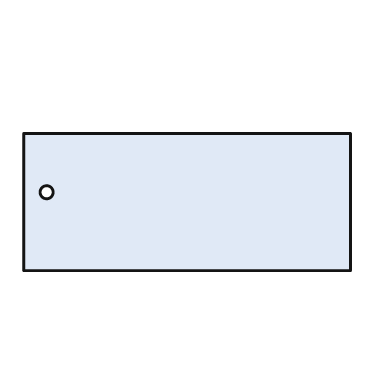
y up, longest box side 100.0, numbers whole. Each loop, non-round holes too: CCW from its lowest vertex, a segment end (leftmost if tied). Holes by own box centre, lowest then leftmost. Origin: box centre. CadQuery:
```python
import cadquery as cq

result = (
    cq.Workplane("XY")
    .moveTo(-50.0, -21.0)
    .lineTo(50.0, -21.0)
    .lineTo(50.0, 21.0)
    .lineTo(-50.0, 21.0)
    .close()
    .moveTo(-43.0, 3.0)
    .circle(2.0)
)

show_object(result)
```